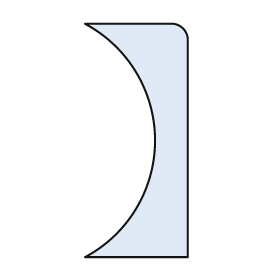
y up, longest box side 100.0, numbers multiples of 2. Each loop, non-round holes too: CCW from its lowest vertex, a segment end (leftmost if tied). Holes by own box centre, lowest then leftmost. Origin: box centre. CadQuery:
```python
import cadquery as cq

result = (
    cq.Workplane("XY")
    .moveTo(-22.0, -50.0)
    .lineTo(22.0, -50.0)
    .lineTo(22.0, 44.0)
    .threePointArc((20.0, 48.0), (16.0, 50.0))
    .lineTo(-22.0, 50.0)
    .threePointArc((8.0, 0.0), (-22.0, -50.0))
    .close()
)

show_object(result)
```